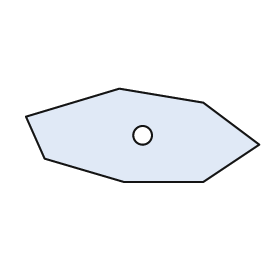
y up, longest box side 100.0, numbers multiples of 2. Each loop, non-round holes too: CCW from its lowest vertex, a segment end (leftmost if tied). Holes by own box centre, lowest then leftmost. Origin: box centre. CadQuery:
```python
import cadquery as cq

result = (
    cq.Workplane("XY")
    .moveTo(-8.0, -20.0)
    .lineTo(26.0, -20.0)
    .lineTo(50.0, -4.0)
    .lineTo(26.0, 14.0)
    .lineTo(-10.0, 20.0)
    .lineTo(-50.0, 8.0)
    .lineTo(-42.0, -10.0)
    .close()
    .moveTo(0.0, 0.0)
    .circle(4.0)
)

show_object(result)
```